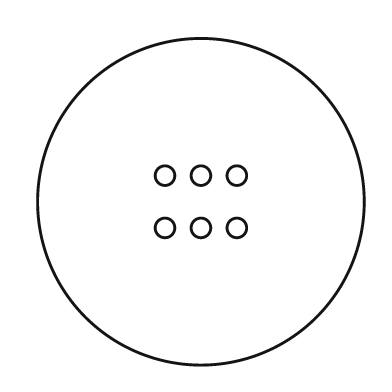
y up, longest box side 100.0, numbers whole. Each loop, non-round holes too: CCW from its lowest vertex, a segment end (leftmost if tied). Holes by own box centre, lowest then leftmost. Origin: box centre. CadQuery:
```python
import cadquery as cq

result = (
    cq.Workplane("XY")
    .moveTo(0.0, 0.0)
    .circle(50.0)
    .moveTo(-11.0, -8.0)
    .circle(3.0)
    .moveTo(0.0, -8.0)
    .circle(3.0)
    .moveTo(11.0, -8.0)
    .circle(3.0)
    .moveTo(-11.0, 8.0)
    .circle(3.0)
    .moveTo(0.0, 8.0)
    .circle(3.0)
    .moveTo(11.0, 8.0)
    .circle(3.0)
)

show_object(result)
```